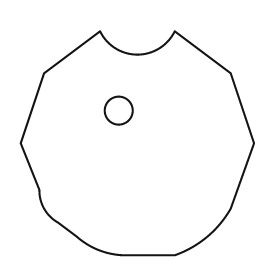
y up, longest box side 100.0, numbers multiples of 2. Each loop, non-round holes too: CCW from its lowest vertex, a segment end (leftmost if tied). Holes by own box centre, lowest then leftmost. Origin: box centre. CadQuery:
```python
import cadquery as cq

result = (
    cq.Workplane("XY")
    .moveTo(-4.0, -48.0)
    .lineTo(16.0, -48.0)
    .threePointArc((30.0, -40.0), (40.0, -28.0))
    .lineTo(50.0, 0.0)
    .lineTo(40.0, 30.0)
    .lineTo(16.0, 48.0)
    .threePointArc((0.0, 38.0), (-16.0, 48.0))
    .lineTo(-40.0, 30.0)
    .lineTo(-50.0, 0.0)
    .lineTo(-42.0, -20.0)
    .threePointArc((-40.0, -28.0), (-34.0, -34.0))
    .lineTo(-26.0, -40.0)
    .threePointArc((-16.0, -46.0), (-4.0, -48.0))
    .close()
    .moveTo(-8.0, 14.0)
    .circle(6.0)
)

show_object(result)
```